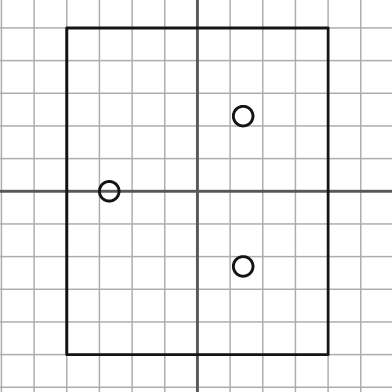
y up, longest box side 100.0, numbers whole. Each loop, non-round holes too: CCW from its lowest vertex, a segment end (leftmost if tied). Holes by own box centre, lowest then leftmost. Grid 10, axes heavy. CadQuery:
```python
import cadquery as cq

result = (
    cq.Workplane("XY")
    .moveTo(-40.0, -50.0)
    .lineTo(40.0, -50.0)
    .lineTo(40.0, 50.0)
    .lineTo(-40.0, 50.0)
    .close()
    .moveTo(14.0, -23.0)
    .circle(3.0)
    .moveTo(-27.0, 0.0)
    .circle(3.0)
    .moveTo(14.0, 23.0)
    .circle(3.0)
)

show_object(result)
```